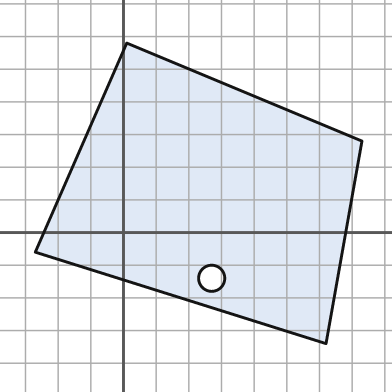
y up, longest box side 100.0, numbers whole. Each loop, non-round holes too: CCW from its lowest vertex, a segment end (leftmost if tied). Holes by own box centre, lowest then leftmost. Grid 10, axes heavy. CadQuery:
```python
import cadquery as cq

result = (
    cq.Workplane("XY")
    .moveTo(62.0, -34.0)
    .lineTo(73.0, 28.0)
    .lineTo(1.0, 58.0)
    .lineTo(-27.0, -6.0)
    .close()
    .moveTo(27.0, -14.0)
    .circle(4.0)
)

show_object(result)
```